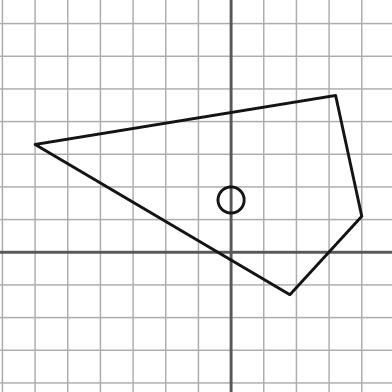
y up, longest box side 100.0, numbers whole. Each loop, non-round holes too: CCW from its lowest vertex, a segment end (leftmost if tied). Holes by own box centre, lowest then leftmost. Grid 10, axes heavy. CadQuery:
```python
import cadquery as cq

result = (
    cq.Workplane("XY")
    .moveTo(18.0, -13.0)
    .lineTo(40.0, 11.0)
    .lineTo(32.0, 48.0)
    .lineTo(-60.0, 33.0)
    .close()
    .moveTo(0.0, 16.0)
    .circle(4.0)
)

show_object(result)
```